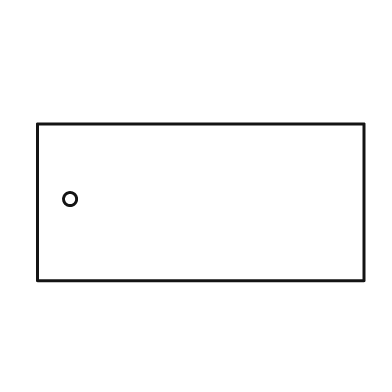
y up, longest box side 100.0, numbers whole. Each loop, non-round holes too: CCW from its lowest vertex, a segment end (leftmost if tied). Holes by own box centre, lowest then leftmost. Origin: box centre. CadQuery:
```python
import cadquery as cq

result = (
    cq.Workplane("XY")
    .moveTo(-50.0, -24.0)
    .lineTo(50.0, -24.0)
    .lineTo(50.0, 24.0)
    .lineTo(-50.0, 24.0)
    .close()
    .moveTo(-40.0, 1.0)
    .circle(2.0)
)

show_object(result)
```